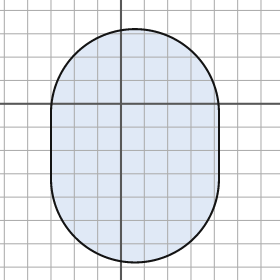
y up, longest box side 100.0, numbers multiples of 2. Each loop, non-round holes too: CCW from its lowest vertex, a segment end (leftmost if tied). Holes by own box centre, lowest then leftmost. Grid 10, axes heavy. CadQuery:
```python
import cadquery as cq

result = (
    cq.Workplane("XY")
    .moveTo(-30.0, -32.0)
    .threePointArc((6.0, -68.0), (42.0, -32.0))
    .lineTo(42.0, -4.0)
    .threePointArc((6.0, 32.0), (-30.0, -4.0))
    .close()
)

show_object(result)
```